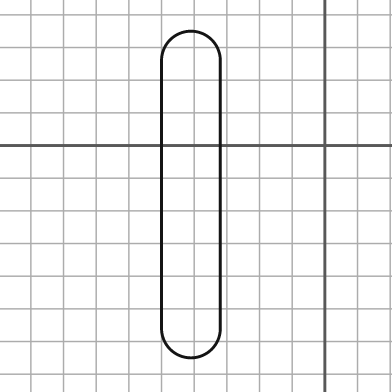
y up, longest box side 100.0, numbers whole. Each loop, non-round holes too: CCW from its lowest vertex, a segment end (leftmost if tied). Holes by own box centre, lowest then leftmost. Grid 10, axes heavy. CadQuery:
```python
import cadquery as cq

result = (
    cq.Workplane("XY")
    .moveTo(-50.0, -56.0)
    .threePointArc((-41.0, -65.0), (-32.0, -56.0))
    .lineTo(-32.0, 26.0)
    .threePointArc((-41.0, 35.0), (-50.0, 26.0))
    .close()
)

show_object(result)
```